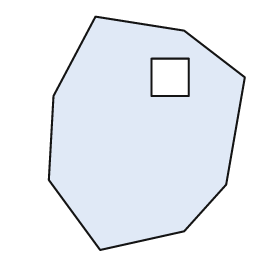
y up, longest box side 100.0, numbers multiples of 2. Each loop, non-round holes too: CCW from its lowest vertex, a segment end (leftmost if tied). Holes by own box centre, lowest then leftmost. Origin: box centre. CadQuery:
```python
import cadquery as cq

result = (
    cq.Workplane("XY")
    .moveTo(-20.0, -50.0)
    .lineTo(16.0, -42.0)
    .lineTo(34.0, -22.0)
    .lineTo(42.0, 24.0)
    .lineTo(16.0, 44.0)
    .lineTo(-22.0, 50.0)
    .lineTo(-40.0, 16.0)
    .lineTo(-42.0, -20.0)
    .close()
    .moveTo(2.0, 16.0)
    .lineTo(18.0, 16.0)
    .lineTo(18.0, 32.0)
    .lineTo(2.0, 32.0)
    .close()
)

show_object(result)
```